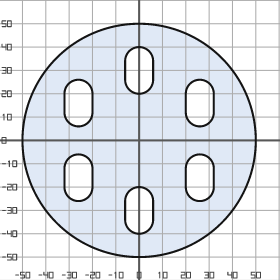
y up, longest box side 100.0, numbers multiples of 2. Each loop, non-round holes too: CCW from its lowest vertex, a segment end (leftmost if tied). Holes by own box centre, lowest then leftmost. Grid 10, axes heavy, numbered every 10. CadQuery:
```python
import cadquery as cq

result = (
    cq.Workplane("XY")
    .moveTo(0.0, 0.0)
    .circle(50.0)
    .moveTo(-6.0, -34.0)
    .threePointArc((0.0, -40.0), (6.0, -34.0))
    .lineTo(6.0, -26.0)
    .threePointArc((0.0, -20.0), (-6.0, -26.0))
    .close()
    .moveTo(-32.0, -20.0)
    .threePointArc((-26.0, -26.0), (-20.0, -20.0))
    .lineTo(-20.0, -12.0)
    .threePointArc((-26.0, -6.0), (-32.0, -12.0))
    .close()
    .moveTo(20.0, -20.0)
    .threePointArc((26.0, -26.0), (32.0, -20.0))
    .lineTo(32.0, -12.0)
    .threePointArc((26.0, -6.0), (20.0, -12.0))
    .close()
    .moveTo(-32.0, 12.0)
    .threePointArc((-26.0, 6.0), (-20.0, 12.0))
    .lineTo(-20.0, 20.0)
    .threePointArc((-26.0, 26.0), (-32.0, 20.0))
    .close()
    .moveTo(20.0, 12.0)
    .threePointArc((26.0, 6.0), (32.0, 12.0))
    .lineTo(32.0, 20.0)
    .threePointArc((26.0, 26.0), (20.0, 20.0))
    .close()
    .moveTo(-6.0, 26.0)
    .threePointArc((0.0, 20.0), (6.0, 26.0))
    .lineTo(6.0, 34.0)
    .threePointArc((0.0, 40.0), (-6.0, 34.0))
    .close()
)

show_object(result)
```